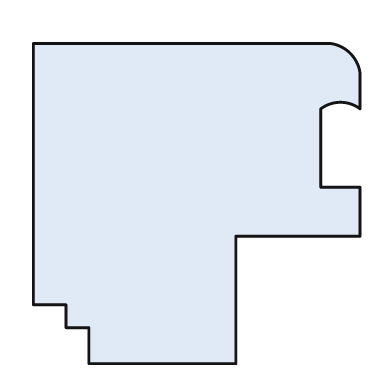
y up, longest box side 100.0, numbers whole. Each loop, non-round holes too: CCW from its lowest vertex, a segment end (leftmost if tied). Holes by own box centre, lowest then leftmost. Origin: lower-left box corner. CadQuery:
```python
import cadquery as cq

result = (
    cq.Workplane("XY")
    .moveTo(17.0, 0.0)
    .lineTo(62.0, 0.0)
    .lineTo(62.0, 39.0)
    .lineTo(100.0, 39.0)
    .lineTo(100.0, 54.0)
    .lineTo(88.0, 54.0)
    .lineTo(88.0, 78.0)
    .threePointArc((94.0, 80.0), (100.0, 78.0))
    .lineTo(100.0, 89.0)
    .threePointArc((97.0, 95.0), (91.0, 98.0))
    .lineTo(0.0, 98.0)
    .lineTo(0.0, 18.0)
    .lineTo(10.0, 18.0)
    .lineTo(10.0, 11.0)
    .lineTo(17.0, 11.0)
    .close()
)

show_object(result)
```